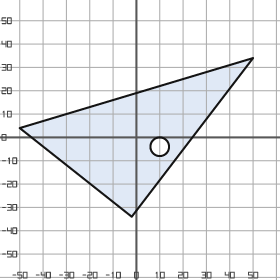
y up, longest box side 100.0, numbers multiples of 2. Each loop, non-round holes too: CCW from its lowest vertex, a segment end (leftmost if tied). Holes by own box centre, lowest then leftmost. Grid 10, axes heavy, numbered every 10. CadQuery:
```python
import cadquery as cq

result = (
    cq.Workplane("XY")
    .moveTo(-2.0, -34.0)
    .lineTo(50.0, 34.0)
    .lineTo(-50.0, 4.0)
    .close()
    .moveTo(10.0, -4.0)
    .circle(4.0)
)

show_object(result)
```